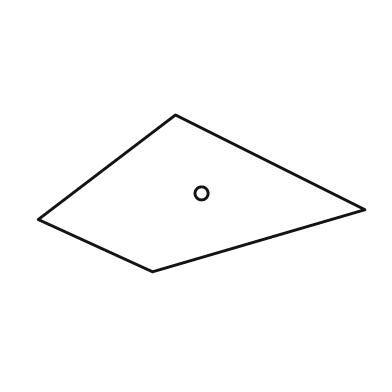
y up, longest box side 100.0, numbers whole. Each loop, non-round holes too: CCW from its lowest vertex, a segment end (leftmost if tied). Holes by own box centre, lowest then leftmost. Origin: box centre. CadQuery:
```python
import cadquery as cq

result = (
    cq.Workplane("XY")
    .moveTo(-15.0, -24.0)
    .lineTo(50.0, -5.0)
    .lineTo(-8.0, 24.0)
    .lineTo(-50.0, -8.0)
    .close()
    .moveTo(0.0, 0.0)
    .circle(2.0)
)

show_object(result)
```